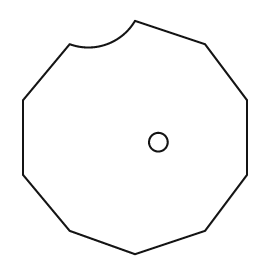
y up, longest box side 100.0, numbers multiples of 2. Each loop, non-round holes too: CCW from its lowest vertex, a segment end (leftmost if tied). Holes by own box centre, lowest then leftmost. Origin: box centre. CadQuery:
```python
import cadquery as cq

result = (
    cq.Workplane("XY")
    .moveTo(0.0, -50.0)
    .lineTo(30.0, -40.0)
    .lineTo(48.0, -16.0)
    .lineTo(48.0, 16.0)
    .lineTo(30.0, 40.0)
    .lineTo(0.0, 50.0)
    .threePointArc((-12.0, 40.0), (-28.0, 40.0))
    .lineTo(-48.0, 16.0)
    .lineTo(-48.0, -16.0)
    .lineTo(-28.0, -40.0)
    .close()
    .moveTo(10.0, -2.0)
    .circle(4.0)
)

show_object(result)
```